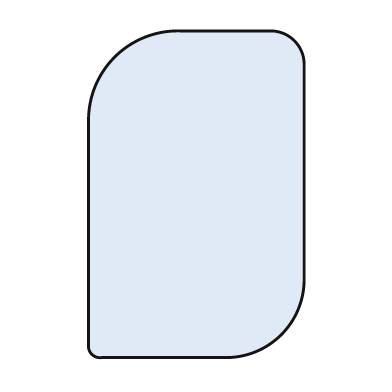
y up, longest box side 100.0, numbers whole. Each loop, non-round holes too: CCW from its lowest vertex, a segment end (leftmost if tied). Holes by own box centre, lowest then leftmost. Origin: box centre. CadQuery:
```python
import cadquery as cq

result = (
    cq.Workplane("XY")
    .moveTo(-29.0, -50.0)
    .lineTo(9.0, -50.0)
    .threePointArc((26.0, -43.0), (33.0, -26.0))
    .lineTo(33.0, 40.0)
    .threePointArc((30.0, 47.0), (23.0, 50.0))
    .lineTo(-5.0, 50.0)
    .threePointArc((-25.0, 42.0), (-33.0, 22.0))
    .lineTo(-33.0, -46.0)
    .threePointArc((-32.0, -49.0), (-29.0, -50.0))
    .close()
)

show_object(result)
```